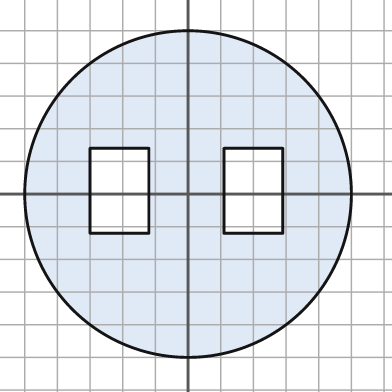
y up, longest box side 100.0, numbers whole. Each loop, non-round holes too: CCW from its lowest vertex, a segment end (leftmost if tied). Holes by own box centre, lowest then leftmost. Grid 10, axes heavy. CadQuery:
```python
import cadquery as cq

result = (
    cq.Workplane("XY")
    .moveTo(0.0, 0.0)
    .circle(50.0)
    .moveTo(-30.0, -12.0)
    .lineTo(-12.0, -12.0)
    .lineTo(-12.0, 14.0)
    .lineTo(-30.0, 14.0)
    .close()
    .moveTo(11.0, -12.0)
    .lineTo(29.0, -12.0)
    .lineTo(29.0, 14.0)
    .lineTo(11.0, 14.0)
    .close()
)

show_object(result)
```